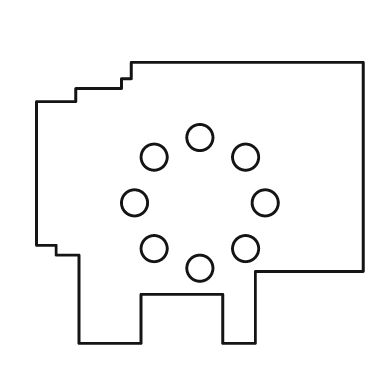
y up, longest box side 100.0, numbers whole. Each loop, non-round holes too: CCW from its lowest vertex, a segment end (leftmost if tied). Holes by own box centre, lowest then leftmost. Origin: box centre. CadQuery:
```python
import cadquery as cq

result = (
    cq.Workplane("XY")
    .moveTo(-37.0, -43.0)
    .lineTo(-18.0, -43.0)
    .lineTo(-18.0, -28.0)
    .lineTo(7.0, -28.0)
    .lineTo(7.0, -43.0)
    .lineTo(17.0, -43.0)
    .lineTo(17.0, -21.0)
    .lineTo(50.0, -21.0)
    .lineTo(50.0, 43.0)
    .lineTo(-21.0, 43.0)
    .lineTo(-21.0, 38.0)
    .lineTo(-24.0, 38.0)
    .lineTo(-24.0, 35.0)
    .lineTo(-38.0, 35.0)
    .lineTo(-38.0, 31.0)
    .lineTo(-50.0, 31.0)
    .lineTo(-50.0, -13.0)
    .lineTo(-44.0, -13.0)
    .lineTo(-44.0, -16.0)
    .lineTo(-37.0, -16.0)
    .close()
    .moveTo(0.0, -20.0)
    .circle(4.0)
    .moveTo(-14.0, -14.0)
    .circle(4.0)
    .moveTo(14.0, -14.0)
    .circle(4.0)
    .moveTo(-20.0, 0.0)
    .circle(4.0)
    .moveTo(20.0, 0.0)
    .circle(4.0)
    .moveTo(-14.0, 14.0)
    .circle(4.0)
    .moveTo(14.0, 14.0)
    .circle(4.0)
    .moveTo(0.0, 20.0)
    .circle(4.0)
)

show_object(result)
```